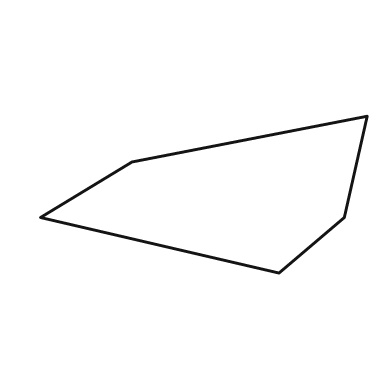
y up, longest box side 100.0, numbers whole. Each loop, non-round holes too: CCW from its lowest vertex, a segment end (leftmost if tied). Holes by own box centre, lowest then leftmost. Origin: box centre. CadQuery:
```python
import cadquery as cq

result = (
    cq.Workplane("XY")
    .moveTo(23.0, -24.0)
    .lineTo(43.0, -7.0)
    .lineTo(50.0, 24.0)
    .lineTo(-22.0, 10.0)
    .lineTo(-50.0, -7.0)
    .close()
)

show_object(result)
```